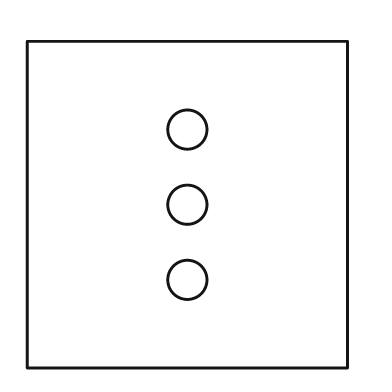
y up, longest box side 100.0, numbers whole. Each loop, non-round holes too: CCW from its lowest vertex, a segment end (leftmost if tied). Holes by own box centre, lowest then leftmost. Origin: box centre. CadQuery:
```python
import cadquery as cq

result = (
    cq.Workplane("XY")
    .moveTo(-49.0, -50.0)
    .lineTo(49.0, -50.0)
    .lineTo(49.0, 50.0)
    .lineTo(-49.0, 50.0)
    .close()
    .moveTo(0.0, -23.0)
    .circle(6.0)
    .moveTo(0.0, 0.0)
    .circle(6.0)
    .moveTo(0.0, 23.0)
    .circle(6.0)
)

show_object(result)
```